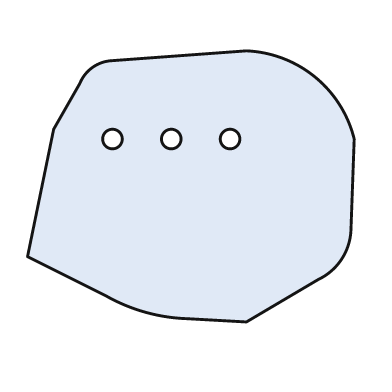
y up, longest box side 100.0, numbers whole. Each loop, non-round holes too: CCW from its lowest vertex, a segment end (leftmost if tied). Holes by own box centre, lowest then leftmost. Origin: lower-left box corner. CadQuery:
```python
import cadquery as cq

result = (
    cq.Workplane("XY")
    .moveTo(67.0, 0.0)
    .lineTo(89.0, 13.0)
    .threePointArc((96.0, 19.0), (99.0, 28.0))
    .lineTo(100.0, 56.0)
    .threePointArc((88.0, 75.0), (67.0, 83.0))
    .lineTo(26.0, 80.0)
    .threePointArc((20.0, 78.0), (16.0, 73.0))
    .lineTo(8.0, 59.0)
    .lineTo(0.0, 20.0)
    .lineTo(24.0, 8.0)
    .threePointArc((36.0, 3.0), (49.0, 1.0))
    .close()
    .moveTo(26.0, 56.0)
    .circle(3.0)
    .moveTo(44.0, 56.0)
    .circle(3.0)
    .moveTo(62.0, 56.0)
    .circle(3.0)
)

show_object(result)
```